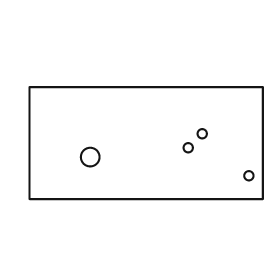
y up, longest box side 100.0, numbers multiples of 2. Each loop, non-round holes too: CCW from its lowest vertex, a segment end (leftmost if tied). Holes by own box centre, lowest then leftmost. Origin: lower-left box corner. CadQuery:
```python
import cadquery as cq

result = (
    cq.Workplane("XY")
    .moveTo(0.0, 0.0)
    .lineTo(100.0, 0.0)
    .lineTo(100.0, 48.0)
    .lineTo(0.0, 48.0)
    .close()
    .moveTo(94.0, 10.0)
    .circle(2.0)
    .moveTo(26.0, 18.0)
    .circle(4.0)
    .moveTo(68.0, 22.0)
    .circle(2.0)
    .moveTo(74.0, 28.0)
    .circle(2.0)
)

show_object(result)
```